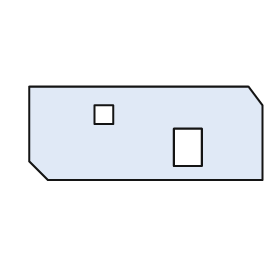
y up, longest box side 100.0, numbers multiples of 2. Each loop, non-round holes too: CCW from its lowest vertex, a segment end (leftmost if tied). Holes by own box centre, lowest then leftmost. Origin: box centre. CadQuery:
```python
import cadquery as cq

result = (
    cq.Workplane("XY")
    .moveTo(-42.0, -20.0)
    .lineTo(50.0, -20.0)
    .lineTo(50.0, 12.0)
    .lineTo(44.0, 20.0)
    .lineTo(-50.0, 20.0)
    .lineTo(-50.0, -12.0)
    .close()
    .moveTo(12.0, -14.0)
    .lineTo(24.0, -14.0)
    .lineTo(24.0, 2.0)
    .lineTo(12.0, 2.0)
    .close()
    .moveTo(-22.0, 4.0)
    .lineTo(-14.0, 4.0)
    .lineTo(-14.0, 12.0)
    .lineTo(-22.0, 12.0)
    .close()
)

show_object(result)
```